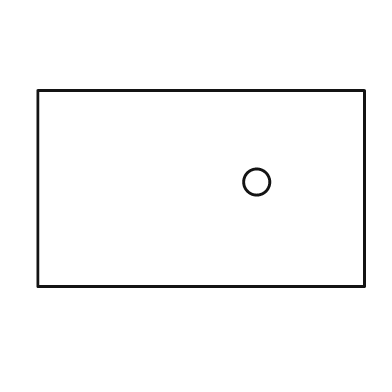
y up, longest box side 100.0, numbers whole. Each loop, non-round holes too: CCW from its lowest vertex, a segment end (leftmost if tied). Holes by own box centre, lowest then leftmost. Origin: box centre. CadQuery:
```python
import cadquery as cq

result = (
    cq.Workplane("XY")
    .moveTo(-50.0, -30.0)
    .lineTo(50.0, -30.0)
    .lineTo(50.0, 30.0)
    .lineTo(-50.0, 30.0)
    .close()
    .moveTo(17.0, 2.0)
    .circle(4.0)
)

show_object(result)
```